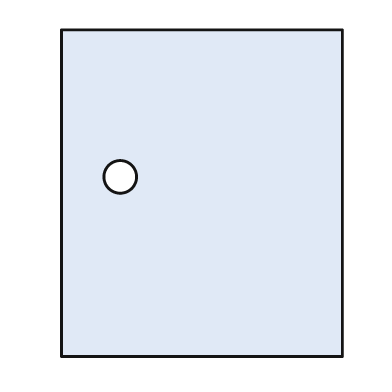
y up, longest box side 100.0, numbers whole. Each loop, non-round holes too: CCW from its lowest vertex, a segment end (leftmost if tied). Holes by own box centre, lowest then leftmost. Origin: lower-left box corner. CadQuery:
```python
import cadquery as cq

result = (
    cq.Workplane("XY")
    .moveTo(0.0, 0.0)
    .lineTo(86.0, 0.0)
    .lineTo(86.0, 100.0)
    .lineTo(0.0, 100.0)
    .close()
    .moveTo(18.0, 55.0)
    .circle(5.0)
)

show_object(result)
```